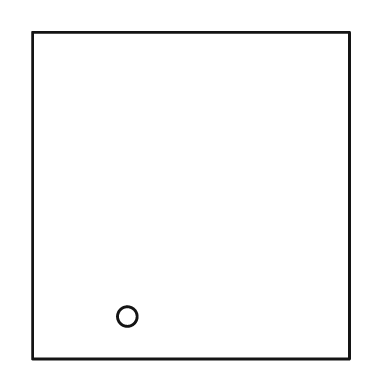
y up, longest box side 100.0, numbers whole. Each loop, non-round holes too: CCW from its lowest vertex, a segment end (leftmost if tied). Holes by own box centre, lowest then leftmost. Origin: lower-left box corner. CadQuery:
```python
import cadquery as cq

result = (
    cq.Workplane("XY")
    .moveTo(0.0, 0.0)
    .lineTo(97.0, 0.0)
    .lineTo(97.0, 100.0)
    .lineTo(0.0, 100.0)
    .close()
    .moveTo(29.0, 13.0)
    .circle(3.0)
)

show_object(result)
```